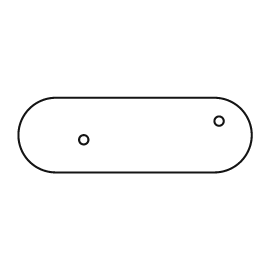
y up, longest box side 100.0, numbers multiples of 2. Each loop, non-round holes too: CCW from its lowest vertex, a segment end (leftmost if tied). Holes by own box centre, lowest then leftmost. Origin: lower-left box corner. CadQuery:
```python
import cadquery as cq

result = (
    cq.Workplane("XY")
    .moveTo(16.0, 0.0)
    .lineTo(84.0, 0.0)
    .threePointArc((100.0, 16.0), (84.0, 32.0))
    .lineTo(16.0, 32.0)
    .threePointArc((0.0, 16.0), (16.0, 0.0))
    .close()
    .moveTo(28.0, 14.0)
    .circle(2.0)
    .moveTo(86.0, 22.0)
    .circle(2.0)
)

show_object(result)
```